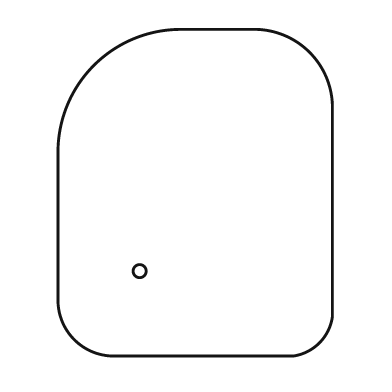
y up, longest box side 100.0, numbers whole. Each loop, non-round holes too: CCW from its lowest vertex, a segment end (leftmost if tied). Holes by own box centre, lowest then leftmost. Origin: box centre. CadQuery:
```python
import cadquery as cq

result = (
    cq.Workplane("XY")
    .moveTo(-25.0, -50.0)
    .lineTo(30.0, -50.0)
    .threePointArc((38.0, -46.0), (42.0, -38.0))
    .lineTo(42.0, 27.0)
    .threePointArc((35.0, 43.0), (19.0, 50.0))
    .lineTo(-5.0, 50.0)
    .threePointArc((-31.0, 39.0), (-42.0, 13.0))
    .lineTo(-42.0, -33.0)
    .threePointArc((-37.0, -45.0), (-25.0, -50.0))
    .close()
    .moveTo(-17.0, -24.0)
    .circle(2.0)
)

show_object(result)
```